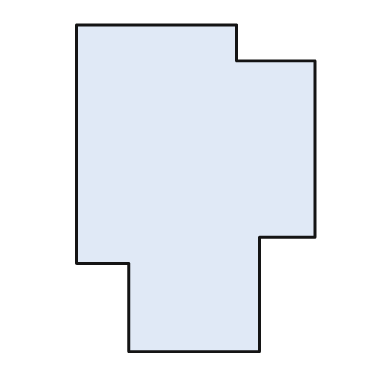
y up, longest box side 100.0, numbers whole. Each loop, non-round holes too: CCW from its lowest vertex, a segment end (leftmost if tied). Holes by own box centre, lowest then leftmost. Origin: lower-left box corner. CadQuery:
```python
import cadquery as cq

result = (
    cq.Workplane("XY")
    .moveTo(16.0, 0.0)
    .lineTo(56.0, 0.0)
    .lineTo(56.0, 35.0)
    .lineTo(73.0, 35.0)
    .lineTo(73.0, 89.0)
    .lineTo(49.0, 89.0)
    .lineTo(49.0, 100.0)
    .lineTo(0.0, 100.0)
    .lineTo(0.0, 27.0)
    .lineTo(16.0, 27.0)
    .close()
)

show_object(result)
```